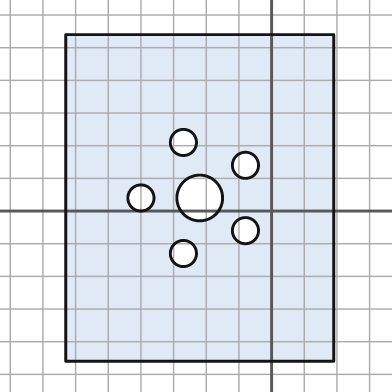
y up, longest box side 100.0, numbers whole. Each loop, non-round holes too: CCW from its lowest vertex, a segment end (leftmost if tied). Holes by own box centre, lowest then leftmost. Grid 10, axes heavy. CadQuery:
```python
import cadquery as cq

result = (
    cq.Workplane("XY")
    .moveTo(-63.0, -46.0)
    .lineTo(19.0, -46.0)
    .lineTo(19.0, 54.0)
    .lineTo(-63.0, 54.0)
    .close()
    .moveTo(-27.0, -13.0)
    .circle(4.0)
    .moveTo(-8.0, -6.0)
    .circle(4.0)
    .moveTo(-40.0, 4.0)
    .circle(4.0)
    .moveTo(-22.0, 4.0)
    .circle(7.0)
    .moveTo(-8.0, 14.0)
    .circle(4.0)
    .moveTo(-27.0, 21.0)
    .circle(4.0)
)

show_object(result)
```